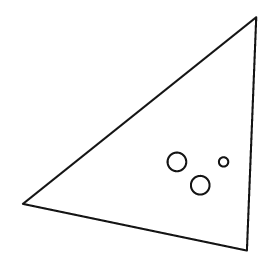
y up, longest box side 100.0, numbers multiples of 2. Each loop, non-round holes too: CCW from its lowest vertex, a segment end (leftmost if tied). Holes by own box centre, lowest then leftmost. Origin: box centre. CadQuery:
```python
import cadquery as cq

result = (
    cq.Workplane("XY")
    .moveTo(46.0, -50.0)
    .lineTo(50.0, 50.0)
    .lineTo(-50.0, -30.0)
    .close()
    .moveTo(26.0, -22.0)
    .circle(4.0)
    .moveTo(16.0, -12.0)
    .circle(4.0)
    .moveTo(36.0, -12.0)
    .circle(2.0)
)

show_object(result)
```